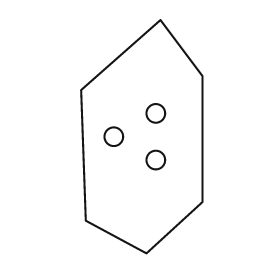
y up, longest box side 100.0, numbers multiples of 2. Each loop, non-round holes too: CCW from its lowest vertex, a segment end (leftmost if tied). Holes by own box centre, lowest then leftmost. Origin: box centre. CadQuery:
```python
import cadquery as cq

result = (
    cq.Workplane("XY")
    .moveTo(2.0, -50.0)
    .lineTo(26.0, -28.0)
    .lineTo(26.0, 26.0)
    .lineTo(8.0, 50.0)
    .lineTo(-26.0, 20.0)
    .lineTo(-24.0, -36.0)
    .close()
    .moveTo(6.0, -10.0)
    .circle(4.0)
    .moveTo(-12.0, 0.0)
    .circle(4.0)
    .moveTo(6.0, 10.0)
    .circle(4.0)
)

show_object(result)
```